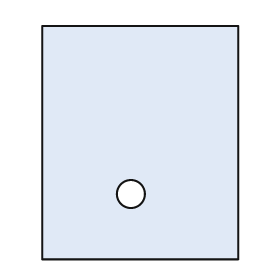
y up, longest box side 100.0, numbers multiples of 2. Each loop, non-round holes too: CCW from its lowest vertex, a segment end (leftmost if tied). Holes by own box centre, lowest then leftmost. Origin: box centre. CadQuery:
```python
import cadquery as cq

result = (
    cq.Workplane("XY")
    .moveTo(-42.0, -50.0)
    .lineTo(42.0, -50.0)
    .lineTo(42.0, 50.0)
    .lineTo(-42.0, 50.0)
    .close()
    .moveTo(-4.0, -22.0)
    .circle(6.0)
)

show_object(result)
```